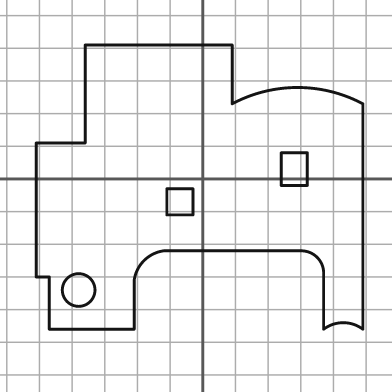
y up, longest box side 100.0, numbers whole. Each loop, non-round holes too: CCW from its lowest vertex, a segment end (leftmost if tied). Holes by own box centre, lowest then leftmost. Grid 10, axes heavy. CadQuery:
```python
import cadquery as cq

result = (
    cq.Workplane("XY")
    .moveTo(-47.0, -46.0)
    .lineTo(-21.0, -46.0)
    .lineTo(-21.0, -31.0)
    .threePointArc((-18.0, -25.0), (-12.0, -22.0))
    .lineTo(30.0, -22.0)
    .threePointArc((35.0, -24.0), (37.0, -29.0))
    .lineTo(37.0, -46.0)
    .threePointArc((43.0, -44.0), (49.0, -46.0))
    .lineTo(49.0, 23.0)
    .threePointArc((29.0, 28.0), (9.0, 23.0))
    .lineTo(9.0, 41.0)
    .lineTo(-36.0, 41.0)
    .lineTo(-36.0, 11.0)
    .lineTo(-51.0, 11.0)
    .lineTo(-51.0, -30.0)
    .lineTo(-47.0, -30.0)
    .close()
    .moveTo(-38.0, -34.0)
    .circle(5.0)
    .moveTo(-11.0, -11.0)
    .lineTo(-3.0, -11.0)
    .lineTo(-3.0, -3.0)
    .lineTo(-11.0, -3.0)
    .close()
    .moveTo(24.0, -2.0)
    .lineTo(32.0, -2.0)
    .lineTo(32.0, 8.0)
    .lineTo(24.0, 8.0)
    .close()
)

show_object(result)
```